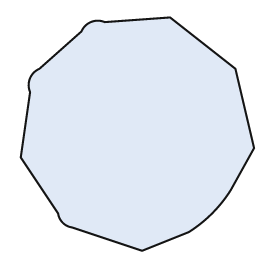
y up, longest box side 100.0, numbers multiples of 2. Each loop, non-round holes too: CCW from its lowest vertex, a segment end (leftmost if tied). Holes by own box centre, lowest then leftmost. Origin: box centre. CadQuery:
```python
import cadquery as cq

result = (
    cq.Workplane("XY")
    .moveTo(2.0, -50.0)
    .lineTo(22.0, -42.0)
    .threePointArc((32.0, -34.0), (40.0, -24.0))
    .lineTo(50.0, -6.0)
    .lineTo(42.0, 28.0)
    .lineTo(14.0, 50.0)
    .lineTo(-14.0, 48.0)
    .threePointArc((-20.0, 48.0), (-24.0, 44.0))
    .lineTo(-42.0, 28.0)
    .threePointArc((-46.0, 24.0), (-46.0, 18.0))
    .lineTo(-50.0, -10.0)
    .lineTo(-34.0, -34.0)
    .threePointArc((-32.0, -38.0), (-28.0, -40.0))
    .close()
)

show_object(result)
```